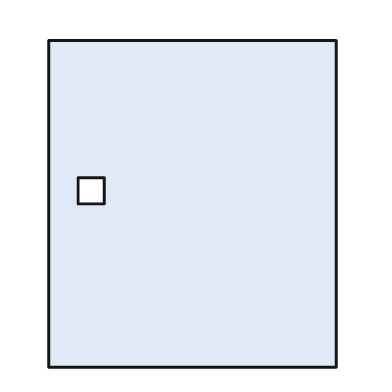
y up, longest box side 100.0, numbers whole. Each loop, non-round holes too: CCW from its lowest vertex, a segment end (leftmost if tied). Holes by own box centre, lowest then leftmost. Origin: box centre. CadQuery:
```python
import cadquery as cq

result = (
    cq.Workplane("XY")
    .moveTo(-44.0, -50.0)
    .lineTo(44.0, -50.0)
    .lineTo(44.0, 50.0)
    .lineTo(-44.0, 50.0)
    .close()
    .moveTo(-35.0, 0.0)
    .lineTo(-27.0, 0.0)
    .lineTo(-27.0, 8.0)
    .lineTo(-35.0, 8.0)
    .close()
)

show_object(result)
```